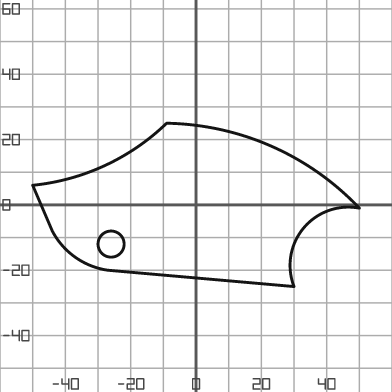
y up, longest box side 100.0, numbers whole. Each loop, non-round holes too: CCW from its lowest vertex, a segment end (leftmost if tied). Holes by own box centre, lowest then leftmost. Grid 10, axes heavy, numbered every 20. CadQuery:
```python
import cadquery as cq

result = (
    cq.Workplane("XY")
    .moveTo(30.0, -25.0)
    .threePointArc((33.0, -7.0), (50.0, -1.0))
    .threePointArc((23.0, 18.0), (-9.0, 25.0))
    .threePointArc((-28.0, 12.0), (-50.0, 6.0))
    .lineTo(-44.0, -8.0)
    .threePointArc((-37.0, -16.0), (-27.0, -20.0))
    .close()
    .moveTo(-26.0, -12.0)
    .circle(4.0)
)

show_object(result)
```